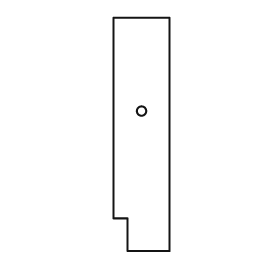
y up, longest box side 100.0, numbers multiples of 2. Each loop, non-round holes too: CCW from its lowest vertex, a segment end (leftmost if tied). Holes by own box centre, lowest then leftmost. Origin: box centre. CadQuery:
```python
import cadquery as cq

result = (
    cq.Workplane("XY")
    .moveTo(-6.0, -50.0)
    .lineTo(12.0, -50.0)
    .lineTo(12.0, 50.0)
    .lineTo(-12.0, 50.0)
    .lineTo(-12.0, -36.0)
    .lineTo(-6.0, -36.0)
    .close()
    .moveTo(0.0, 10.0)
    .circle(2.0)
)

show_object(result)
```